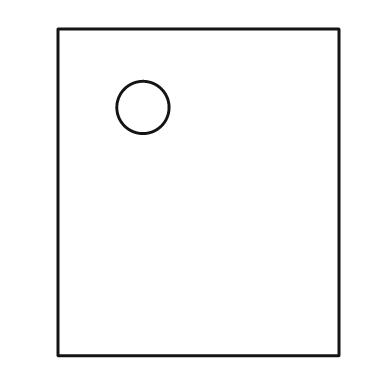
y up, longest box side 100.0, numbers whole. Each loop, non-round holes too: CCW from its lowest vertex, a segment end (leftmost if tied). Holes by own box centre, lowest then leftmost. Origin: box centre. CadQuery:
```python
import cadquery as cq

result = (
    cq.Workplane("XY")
    .moveTo(-43.0, -50.0)
    .lineTo(43.0, -50.0)
    .lineTo(43.0, 50.0)
    .lineTo(-43.0, 50.0)
    .close()
    .moveTo(-17.0, 26.0)
    .circle(8.0)
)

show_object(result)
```